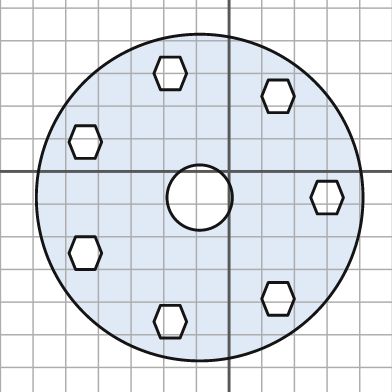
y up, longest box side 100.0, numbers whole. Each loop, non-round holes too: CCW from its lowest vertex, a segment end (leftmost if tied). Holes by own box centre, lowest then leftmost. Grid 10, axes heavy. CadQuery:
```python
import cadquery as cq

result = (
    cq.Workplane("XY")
    .moveTo(-9.0, -8.0)
    .circle(50.0)
    .moveTo(-21.0, -51.0)
    .lineTo(-15.0, -51.0)
    .lineTo(-13.0, -46.0)
    .lineTo(-15.0, -41.0)
    .lineTo(-21.0, -41.0)
    .lineTo(-23.0, -46.0)
    .close()
    .moveTo(12.0, -44.0)
    .lineTo(18.0, -44.0)
    .lineTo(20.0, -39.0)
    .lineTo(18.0, -34.0)
    .lineTo(12.0, -34.0)
    .lineTo(10.0, -39.0)
    .close()
    .moveTo(-47.0, -30.0)
    .lineTo(-41.0, -30.0)
    .lineTo(-39.0, -25.0)
    .lineTo(-41.0, -20.0)
    .lineTo(-47.0, -20.0)
    .lineTo(-49.0, -25.0)
    .close()
    .moveTo(-9.0, -8.0)
    .circle(10.0)
    .moveTo(27.0, -13.0)
    .lineTo(33.0, -13.0)
    .lineTo(35.0, -8.0)
    .lineTo(33.0, -3.0)
    .lineTo(27.0, -3.0)
    .lineTo(25.0, -8.0)
    .close()
    .moveTo(-47.0, 4.0)
    .lineTo(-41.0, 4.0)
    .lineTo(-39.0, 9.0)
    .lineTo(-41.0, 14.0)
    .lineTo(-47.0, 14.0)
    .lineTo(-49.0, 9.0)
    .close()
    .moveTo(12.0, 18.0)
    .lineTo(18.0, 18.0)
    .lineTo(20.0, 23.0)
    .lineTo(18.0, 28.0)
    .lineTo(12.0, 28.0)
    .lineTo(10.0, 23.0)
    .close()
    .moveTo(-21.0, 25.0)
    .lineTo(-15.0, 25.0)
    .lineTo(-13.0, 30.0)
    .lineTo(-15.0, 35.0)
    .lineTo(-21.0, 35.0)
    .lineTo(-23.0, 30.0)
    .close()
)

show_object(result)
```